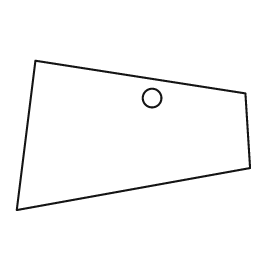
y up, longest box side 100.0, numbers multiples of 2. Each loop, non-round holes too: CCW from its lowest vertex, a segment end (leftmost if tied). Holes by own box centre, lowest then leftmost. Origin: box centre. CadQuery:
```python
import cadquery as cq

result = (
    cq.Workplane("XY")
    .moveTo(-50.0, -32.0)
    .lineTo(50.0, -14.0)
    .lineTo(48.0, 18.0)
    .lineTo(-42.0, 32.0)
    .close()
    .moveTo(8.0, 16.0)
    .circle(4.0)
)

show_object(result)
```